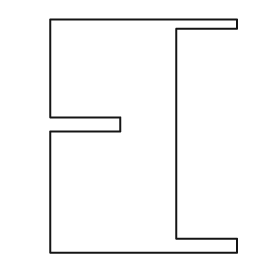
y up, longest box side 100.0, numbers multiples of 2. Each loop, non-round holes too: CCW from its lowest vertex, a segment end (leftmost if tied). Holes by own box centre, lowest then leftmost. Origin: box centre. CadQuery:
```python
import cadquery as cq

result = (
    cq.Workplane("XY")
    .moveTo(-40.0, -50.0)
    .lineTo(40.0, -50.0)
    .lineTo(40.0, -44.0)
    .lineTo(14.0, -44.0)
    .lineTo(14.0, 46.0)
    .lineTo(40.0, 46.0)
    .lineTo(40.0, 50.0)
    .lineTo(-40.0, 50.0)
    .lineTo(-40.0, 8.0)
    .lineTo(-10.0, 8.0)
    .lineTo(-10.0, 2.0)
    .lineTo(-40.0, 2.0)
    .close()
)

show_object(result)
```